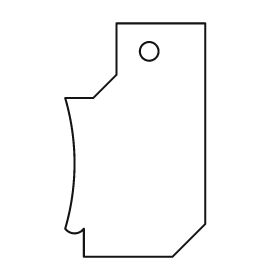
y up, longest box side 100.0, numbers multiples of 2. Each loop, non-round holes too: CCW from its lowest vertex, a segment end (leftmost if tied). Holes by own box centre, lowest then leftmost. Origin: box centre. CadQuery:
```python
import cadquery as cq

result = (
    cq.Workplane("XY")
    .moveTo(-22.0, -50.0)
    .lineTo(16.0, -50.0)
    .lineTo(30.0, -36.0)
    .lineTo(30.0, 50.0)
    .lineTo(-8.0, 50.0)
    .lineTo(-8.0, 28.0)
    .lineTo(-18.0, 18.0)
    .lineTo(-30.0, 18.0)
    .threePointArc((-26.0, -10.0), (-30.0, -38.0))
    .threePointArc((-26.0, -40.0), (-22.0, -38.0))
    .close()
    .moveTo(6.0, 38.0)
    .circle(4.0)
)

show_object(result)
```